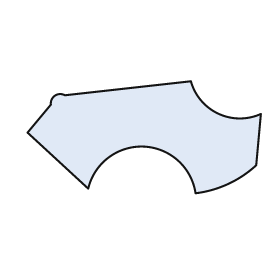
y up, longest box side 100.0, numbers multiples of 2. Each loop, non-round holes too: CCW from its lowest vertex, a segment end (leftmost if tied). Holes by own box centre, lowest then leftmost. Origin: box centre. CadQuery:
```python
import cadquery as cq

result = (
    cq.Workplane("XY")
    .moveTo(22.0, -24.0)
    .threePointArc((36.0, -20.0), (48.0, -12.0))
    .lineTo(50.0, 10.0)
    .threePointArc((32.0, 10.0), (20.0, 24.0))
    .lineTo(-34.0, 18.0)
    .threePointArc((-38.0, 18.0), (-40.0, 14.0))
    .lineTo(-50.0, 2.0)
    .lineTo(-24.0, -22.0)
    .threePointArc((0.0, -4.0), (22.0, -24.0))
    .close()
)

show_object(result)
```